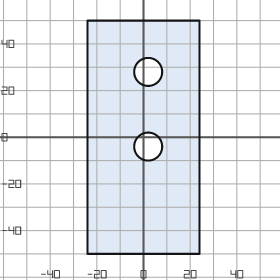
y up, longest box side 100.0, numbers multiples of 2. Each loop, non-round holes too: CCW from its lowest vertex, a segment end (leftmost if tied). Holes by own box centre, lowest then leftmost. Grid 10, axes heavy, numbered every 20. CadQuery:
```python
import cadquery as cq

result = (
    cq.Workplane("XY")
    .moveTo(-24.0, -50.0)
    .lineTo(24.0, -50.0)
    .lineTo(24.0, 50.0)
    .lineTo(-24.0, 50.0)
    .close()
    .moveTo(2.0, -4.0)
    .circle(6.0)
    .moveTo(2.0, 28.0)
    .circle(6.0)
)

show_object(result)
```